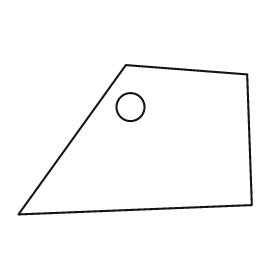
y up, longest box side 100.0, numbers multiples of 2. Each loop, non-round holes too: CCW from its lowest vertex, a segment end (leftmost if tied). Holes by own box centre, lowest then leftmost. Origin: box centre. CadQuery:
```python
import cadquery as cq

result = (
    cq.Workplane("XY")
    .moveTo(-50.0, -32.0)
    .lineTo(50.0, -28.0)
    .lineTo(48.0, 28.0)
    .lineTo(-4.0, 32.0)
    .close()
    .moveTo(-2.0, 14.0)
    .circle(6.0)
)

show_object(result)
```